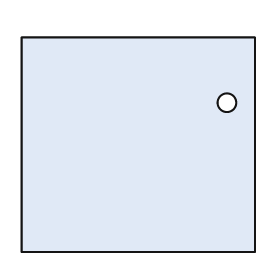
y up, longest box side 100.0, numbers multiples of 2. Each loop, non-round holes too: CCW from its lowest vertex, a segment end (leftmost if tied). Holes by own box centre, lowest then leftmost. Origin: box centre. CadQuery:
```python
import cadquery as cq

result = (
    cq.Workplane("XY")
    .moveTo(-50.0, -46.0)
    .lineTo(50.0, -46.0)
    .lineTo(50.0, 46.0)
    .lineTo(-50.0, 46.0)
    .close()
    .moveTo(38.0, 18.0)
    .circle(4.0)
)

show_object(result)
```